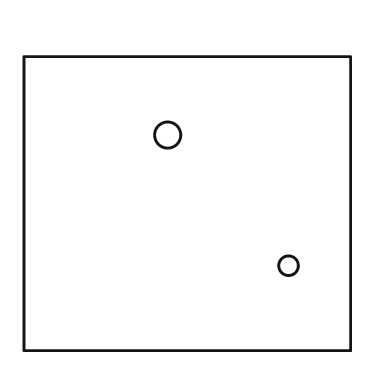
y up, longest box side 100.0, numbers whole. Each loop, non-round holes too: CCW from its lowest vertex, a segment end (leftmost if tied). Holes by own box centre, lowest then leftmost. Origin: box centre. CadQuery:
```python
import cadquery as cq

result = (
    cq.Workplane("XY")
    .moveTo(-50.0, -45.0)
    .lineTo(50.0, -45.0)
    .lineTo(50.0, 45.0)
    .lineTo(-50.0, 45.0)
    .close()
    .moveTo(31.0, -19.0)
    .circle(3.0)
    .moveTo(-6.0, 21.0)
    .circle(4.0)
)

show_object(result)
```